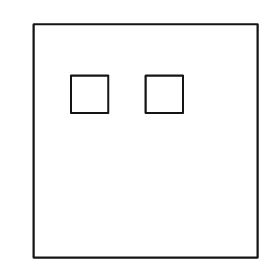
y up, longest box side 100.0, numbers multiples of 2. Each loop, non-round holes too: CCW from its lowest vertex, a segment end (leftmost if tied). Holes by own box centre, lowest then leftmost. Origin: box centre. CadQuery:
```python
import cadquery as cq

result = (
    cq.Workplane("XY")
    .moveTo(-48.0, -50.0)
    .lineTo(48.0, -50.0)
    .lineTo(48.0, 50.0)
    .lineTo(-48.0, 50.0)
    .close()
    .moveTo(-32.0, 12.0)
    .lineTo(-16.0, 12.0)
    .lineTo(-16.0, 28.0)
    .lineTo(-32.0, 28.0)
    .close()
    .moveTo(0.0, 12.0)
    .lineTo(16.0, 12.0)
    .lineTo(16.0, 28.0)
    .lineTo(0.0, 28.0)
    .close()
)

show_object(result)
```